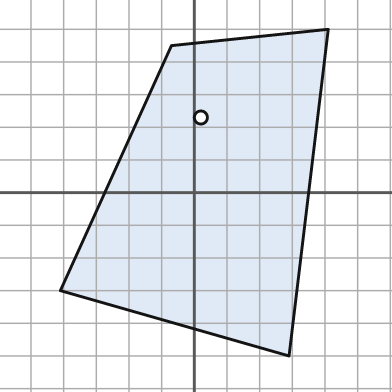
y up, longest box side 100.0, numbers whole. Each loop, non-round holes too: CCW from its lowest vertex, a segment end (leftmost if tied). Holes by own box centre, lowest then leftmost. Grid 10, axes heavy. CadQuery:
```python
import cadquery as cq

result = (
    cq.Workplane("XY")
    .moveTo(29.0, -50.0)
    .lineTo(41.0, 50.0)
    .lineTo(-7.0, 45.0)
    .lineTo(-41.0, -30.0)
    .close()
    .moveTo(2.0, 23.0)
    .circle(2.0)
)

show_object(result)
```